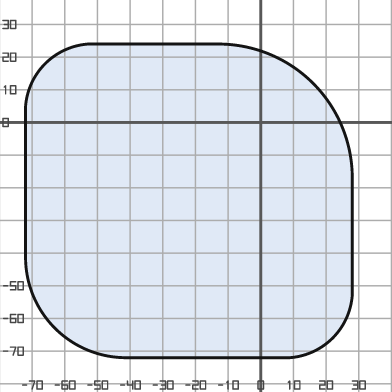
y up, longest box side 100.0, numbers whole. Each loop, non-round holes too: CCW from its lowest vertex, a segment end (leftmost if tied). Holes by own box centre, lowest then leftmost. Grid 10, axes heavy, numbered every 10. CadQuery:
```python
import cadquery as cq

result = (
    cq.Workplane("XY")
    .moveTo(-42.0, -72.0)
    .lineTo(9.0, -72.0)
    .threePointArc((22.0, -66.0), (28.0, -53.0))
    .lineTo(28.0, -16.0)
    .threePointArc((16.0, 12.0), (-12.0, 24.0))
    .lineTo(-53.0, 24.0)
    .threePointArc((-66.0, 18.0), (-72.0, 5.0))
    .lineTo(-72.0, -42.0)
    .threePointArc((-63.0, -63.0), (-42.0, -72.0))
    .close()
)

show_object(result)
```